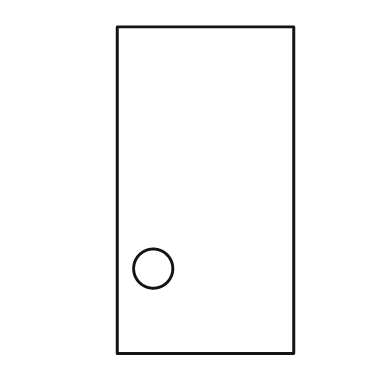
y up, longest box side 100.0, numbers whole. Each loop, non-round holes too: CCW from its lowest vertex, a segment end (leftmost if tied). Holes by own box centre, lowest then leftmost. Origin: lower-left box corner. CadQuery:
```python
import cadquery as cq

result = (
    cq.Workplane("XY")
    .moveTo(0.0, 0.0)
    .lineTo(54.0, 0.0)
    .lineTo(54.0, 100.0)
    .lineTo(0.0, 100.0)
    .close()
    .moveTo(11.0, 26.0)
    .circle(6.0)
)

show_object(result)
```